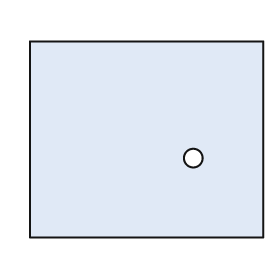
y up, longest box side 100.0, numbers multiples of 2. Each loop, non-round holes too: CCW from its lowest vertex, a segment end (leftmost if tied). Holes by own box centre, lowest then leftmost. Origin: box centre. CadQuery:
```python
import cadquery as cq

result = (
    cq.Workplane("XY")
    .moveTo(-50.0, -42.0)
    .lineTo(50.0, -42.0)
    .lineTo(50.0, 42.0)
    .lineTo(-50.0, 42.0)
    .close()
    .moveTo(20.0, -8.0)
    .circle(4.0)
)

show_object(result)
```